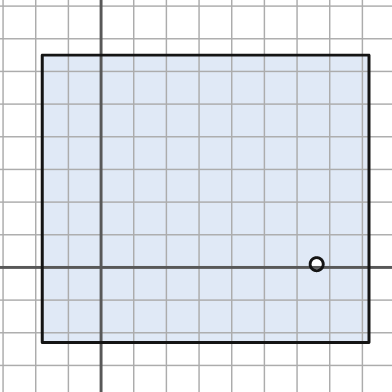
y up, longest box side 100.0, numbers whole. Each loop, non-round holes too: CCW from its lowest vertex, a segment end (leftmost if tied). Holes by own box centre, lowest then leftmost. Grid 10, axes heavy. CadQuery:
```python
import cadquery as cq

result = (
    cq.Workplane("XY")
    .moveTo(-18.0, -23.0)
    .lineTo(82.0, -23.0)
    .lineTo(82.0, 65.0)
    .lineTo(-18.0, 65.0)
    .close()
    .moveTo(66.0, 1.0)
    .circle(2.0)
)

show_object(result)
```